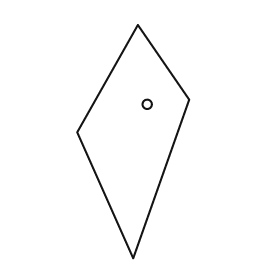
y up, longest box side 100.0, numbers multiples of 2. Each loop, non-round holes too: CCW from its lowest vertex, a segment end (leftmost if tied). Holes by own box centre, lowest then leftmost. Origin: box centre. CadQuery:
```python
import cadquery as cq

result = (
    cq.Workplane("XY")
    .moveTo(0.0, -50.0)
    .lineTo(24.0, 18.0)
    .lineTo(2.0, 50.0)
    .lineTo(-24.0, 4.0)
    .close()
    .moveTo(6.0, 16.0)
    .circle(2.0)
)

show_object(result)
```